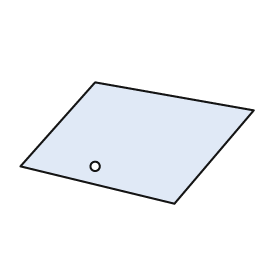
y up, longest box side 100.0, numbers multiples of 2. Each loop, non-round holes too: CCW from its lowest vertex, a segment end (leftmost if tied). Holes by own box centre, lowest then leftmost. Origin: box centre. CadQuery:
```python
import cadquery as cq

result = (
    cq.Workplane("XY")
    .moveTo(16.0, -26.0)
    .lineTo(50.0, 14.0)
    .lineTo(-18.0, 26.0)
    .lineTo(-50.0, -10.0)
    .close()
    .moveTo(-18.0, -10.0)
    .circle(2.0)
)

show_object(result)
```